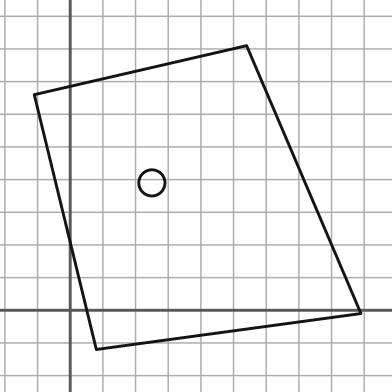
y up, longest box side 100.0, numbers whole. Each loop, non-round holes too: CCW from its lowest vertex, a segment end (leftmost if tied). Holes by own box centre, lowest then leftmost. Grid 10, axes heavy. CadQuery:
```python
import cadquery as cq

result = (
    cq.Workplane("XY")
    .moveTo(8.0, -12.0)
    .lineTo(89.0, -1.0)
    .lineTo(54.0, 81.0)
    .lineTo(-11.0, 66.0)
    .close()
    .moveTo(25.0, 39.0)
    .circle(4.0)
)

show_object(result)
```